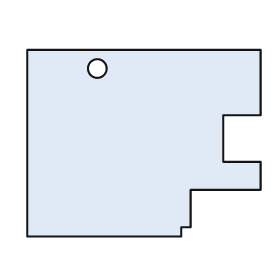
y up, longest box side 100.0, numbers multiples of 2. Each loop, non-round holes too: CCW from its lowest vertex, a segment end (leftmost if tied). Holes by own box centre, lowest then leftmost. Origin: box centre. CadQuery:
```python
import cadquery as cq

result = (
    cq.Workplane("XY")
    .moveTo(-50.0, -40.0)
    .lineTo(16.0, -40.0)
    .lineTo(16.0, -36.0)
    .lineTo(20.0, -36.0)
    .lineTo(20.0, -20.0)
    .lineTo(50.0, -20.0)
    .lineTo(50.0, -8.0)
    .lineTo(34.0, -8.0)
    .lineTo(34.0, 12.0)
    .lineTo(50.0, 12.0)
    .lineTo(50.0, 40.0)
    .lineTo(-50.0, 40.0)
    .close()
    .moveTo(-20.0, 32.0)
    .circle(4.0)
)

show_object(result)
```